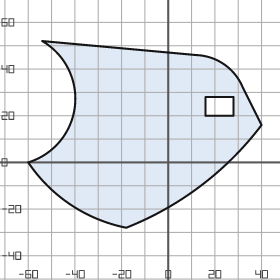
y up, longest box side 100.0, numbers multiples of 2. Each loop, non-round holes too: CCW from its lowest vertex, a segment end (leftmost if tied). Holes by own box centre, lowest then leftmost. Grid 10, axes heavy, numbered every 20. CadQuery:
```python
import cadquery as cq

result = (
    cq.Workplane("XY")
    .moveTo(-18.0, -28.0)
    .threePointArc((14.0, -10.0), (40.0, 16.0))
    .lineTo(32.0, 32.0)
    .threePointArc((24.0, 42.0), (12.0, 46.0))
    .lineTo(-54.0, 52.0)
    .threePointArc((-40.0, 24.0), (-60.0, 0.0))
    .threePointArc((-42.0, -18.0), (-18.0, -28.0))
    .close()
    .moveTo(16.0, 20.0)
    .lineTo(28.0, 20.0)
    .lineTo(28.0, 28.0)
    .lineTo(16.0, 28.0)
    .close()
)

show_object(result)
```